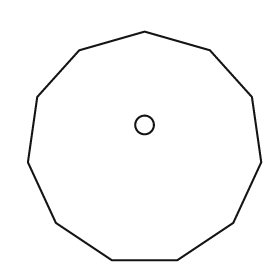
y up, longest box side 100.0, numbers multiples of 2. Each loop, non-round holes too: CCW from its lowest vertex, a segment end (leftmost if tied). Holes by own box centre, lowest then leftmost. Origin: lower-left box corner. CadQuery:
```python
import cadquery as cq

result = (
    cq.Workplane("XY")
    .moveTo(36.0, 0.0)
    .lineTo(64.0, 0.0)
    .lineTo(88.0, 16.0)
    .lineTo(100.0, 42.0)
    .lineTo(96.0, 70.0)
    .lineTo(78.0, 90.0)
    .lineTo(50.0, 98.0)
    .lineTo(22.0, 90.0)
    .lineTo(4.0, 70.0)
    .lineTo(0.0, 42.0)
    .lineTo(12.0, 16.0)
    .close()
    .moveTo(50.0, 58.0)
    .circle(4.0)
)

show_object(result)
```